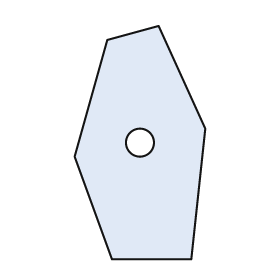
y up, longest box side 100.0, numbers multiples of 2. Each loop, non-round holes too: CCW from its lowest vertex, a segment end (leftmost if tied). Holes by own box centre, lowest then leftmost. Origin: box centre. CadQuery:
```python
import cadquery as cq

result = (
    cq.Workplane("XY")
    .moveTo(-12.0, -50.0)
    .lineTo(22.0, -50.0)
    .lineTo(28.0, 6.0)
    .lineTo(8.0, 50.0)
    .lineTo(-14.0, 44.0)
    .lineTo(-28.0, -6.0)
    .close()
    .moveTo(0.0, 0.0)
    .circle(6.0)
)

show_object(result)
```